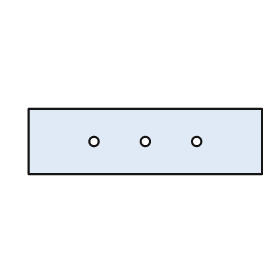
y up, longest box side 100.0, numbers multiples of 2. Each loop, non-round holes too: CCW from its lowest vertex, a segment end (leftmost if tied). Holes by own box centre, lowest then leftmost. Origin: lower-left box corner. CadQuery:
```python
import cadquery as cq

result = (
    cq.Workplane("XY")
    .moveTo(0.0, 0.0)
    .lineTo(100.0, 0.0)
    .lineTo(100.0, 28.0)
    .lineTo(0.0, 28.0)
    .close()
    .moveTo(28.0, 14.0)
    .circle(2.0)
    .moveTo(50.0, 14.0)
    .circle(2.0)
    .moveTo(72.0, 14.0)
    .circle(2.0)
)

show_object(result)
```